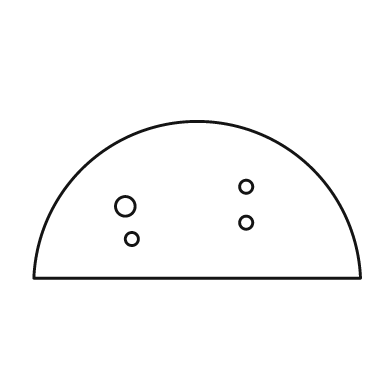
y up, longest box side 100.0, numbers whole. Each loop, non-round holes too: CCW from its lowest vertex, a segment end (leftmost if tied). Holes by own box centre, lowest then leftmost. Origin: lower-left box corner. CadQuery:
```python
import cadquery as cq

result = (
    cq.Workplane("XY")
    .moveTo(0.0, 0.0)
    .lineTo(100.0, 0.0)
    .threePointArc((50.0, 48.0), (0.0, 0.0))
    .close()
    .moveTo(30.0, 12.0)
    .circle(2.0)
    .moveTo(65.0, 17.0)
    .circle(2.0)
    .moveTo(28.0, 22.0)
    .circle(3.0)
    .moveTo(65.0, 28.0)
    .circle(2.0)
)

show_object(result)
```